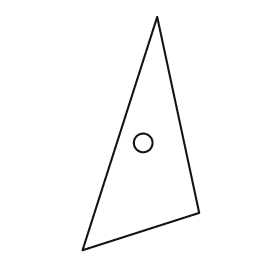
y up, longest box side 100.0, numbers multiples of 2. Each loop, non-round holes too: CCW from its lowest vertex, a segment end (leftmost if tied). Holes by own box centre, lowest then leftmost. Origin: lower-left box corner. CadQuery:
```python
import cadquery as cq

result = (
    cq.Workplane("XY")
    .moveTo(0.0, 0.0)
    .lineTo(50.0, 16.0)
    .lineTo(32.0, 100.0)
    .close()
    .moveTo(26.0, 46.0)
    .circle(4.0)
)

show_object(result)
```